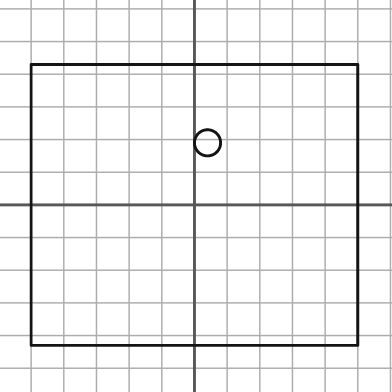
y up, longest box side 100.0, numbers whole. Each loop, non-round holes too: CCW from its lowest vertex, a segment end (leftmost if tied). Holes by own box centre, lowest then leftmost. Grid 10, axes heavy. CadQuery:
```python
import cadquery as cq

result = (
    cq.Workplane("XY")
    .moveTo(-50.0, -43.0)
    .lineTo(50.0, -43.0)
    .lineTo(50.0, 43.0)
    .lineTo(-50.0, 43.0)
    .close()
    .moveTo(4.0, 19.0)
    .circle(4.0)
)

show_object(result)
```